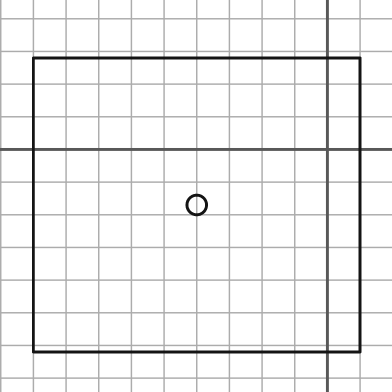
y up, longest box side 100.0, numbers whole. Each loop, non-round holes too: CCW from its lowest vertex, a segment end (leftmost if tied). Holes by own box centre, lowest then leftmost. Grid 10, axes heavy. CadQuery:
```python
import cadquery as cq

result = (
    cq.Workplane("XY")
    .moveTo(-90.0, -62.0)
    .lineTo(10.0, -62.0)
    .lineTo(10.0, 28.0)
    .lineTo(-90.0, 28.0)
    .close()
    .moveTo(-40.0, -17.0)
    .circle(3.0)
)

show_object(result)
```